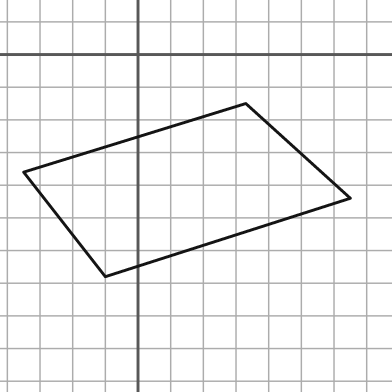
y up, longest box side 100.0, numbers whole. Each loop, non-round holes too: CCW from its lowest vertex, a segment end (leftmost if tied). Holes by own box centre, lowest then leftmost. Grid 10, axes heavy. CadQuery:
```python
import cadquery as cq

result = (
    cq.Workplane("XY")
    .moveTo(-10.0, -68.0)
    .lineTo(65.0, -44.0)
    .lineTo(33.0, -15.0)
    .lineTo(-35.0, -36.0)
    .close()
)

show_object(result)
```